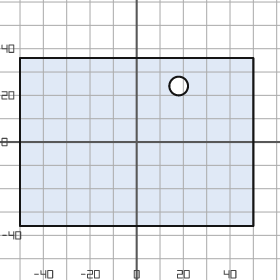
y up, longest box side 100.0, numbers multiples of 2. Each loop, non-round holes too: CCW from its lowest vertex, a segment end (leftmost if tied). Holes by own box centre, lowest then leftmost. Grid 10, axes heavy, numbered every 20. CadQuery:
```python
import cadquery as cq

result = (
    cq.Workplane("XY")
    .moveTo(-50.0, -36.0)
    .lineTo(50.0, -36.0)
    .lineTo(50.0, 36.0)
    .lineTo(-50.0, 36.0)
    .close()
    .moveTo(18.0, 24.0)
    .circle(4.0)
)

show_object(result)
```